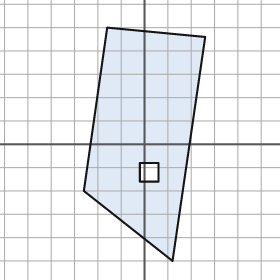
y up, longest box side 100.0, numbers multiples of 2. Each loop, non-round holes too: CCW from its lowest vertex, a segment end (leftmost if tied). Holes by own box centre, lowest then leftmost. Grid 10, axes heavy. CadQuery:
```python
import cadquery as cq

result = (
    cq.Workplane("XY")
    .moveTo(12.0, -50.0)
    .lineTo(26.0, 46.0)
    .lineTo(-16.0, 50.0)
    .lineTo(-26.0, -20.0)
    .close()
    .moveTo(-2.0, -16.0)
    .lineTo(6.0, -16.0)
    .lineTo(6.0, -8.0)
    .lineTo(-2.0, -8.0)
    .close()
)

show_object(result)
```